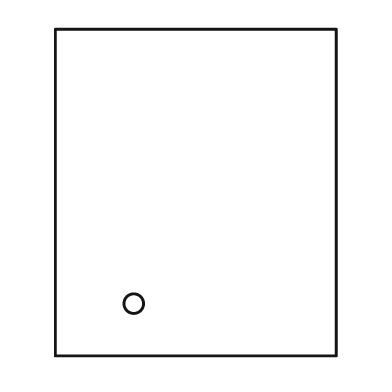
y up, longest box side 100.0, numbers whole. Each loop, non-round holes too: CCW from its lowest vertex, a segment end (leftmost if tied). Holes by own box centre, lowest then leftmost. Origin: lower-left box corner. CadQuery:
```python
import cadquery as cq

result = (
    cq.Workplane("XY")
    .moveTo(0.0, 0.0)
    .lineTo(86.0, 0.0)
    .lineTo(86.0, 100.0)
    .lineTo(0.0, 100.0)
    .close()
    .moveTo(24.0, 16.0)
    .circle(3.0)
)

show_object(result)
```